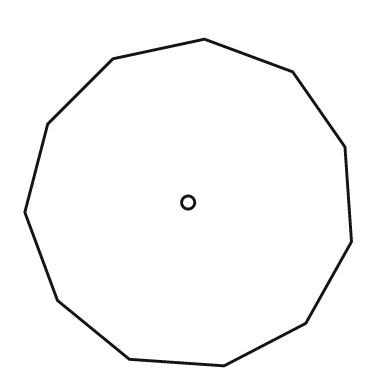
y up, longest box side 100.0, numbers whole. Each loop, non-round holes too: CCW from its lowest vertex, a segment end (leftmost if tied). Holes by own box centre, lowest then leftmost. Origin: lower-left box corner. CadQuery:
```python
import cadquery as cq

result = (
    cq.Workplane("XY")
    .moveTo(61.0, 0.0)
    .lineTo(86.0, 13.0)
    .lineTo(100.0, 38.0)
    .lineTo(98.0, 67.0)
    .lineTo(82.0, 90.0)
    .lineTo(55.0, 100.0)
    .lineTo(27.0, 94.0)
    .lineTo(7.0, 74.0)
    .lineTo(0.0, 47.0)
    .lineTo(10.0, 20.0)
    .lineTo(32.0, 2.0)
    .close()
    .moveTo(50.0, 50.0)
    .circle(2.0)
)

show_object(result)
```